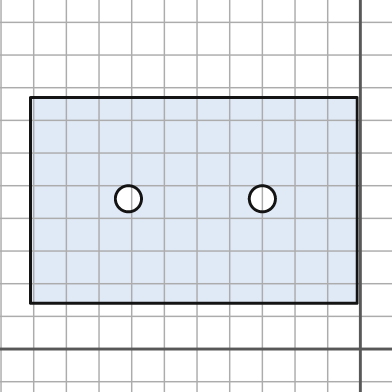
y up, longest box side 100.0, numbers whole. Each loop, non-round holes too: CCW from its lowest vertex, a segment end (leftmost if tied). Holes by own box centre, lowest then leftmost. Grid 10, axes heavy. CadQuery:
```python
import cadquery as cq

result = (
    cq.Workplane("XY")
    .moveTo(-101.0, 14.0)
    .lineTo(-1.0, 14.0)
    .lineTo(-1.0, 77.0)
    .lineTo(-101.0, 77.0)
    .close()
    .moveTo(-71.0, 46.0)
    .circle(4.0)
    .moveTo(-30.0, 46.0)
    .circle(4.0)
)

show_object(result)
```